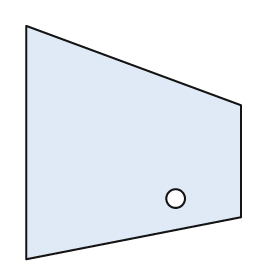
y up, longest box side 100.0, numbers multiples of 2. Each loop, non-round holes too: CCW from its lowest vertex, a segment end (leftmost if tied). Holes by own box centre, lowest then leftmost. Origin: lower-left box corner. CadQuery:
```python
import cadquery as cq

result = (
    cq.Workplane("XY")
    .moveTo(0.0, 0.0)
    .lineTo(92.0, 18.0)
    .lineTo(92.0, 66.0)
    .lineTo(0.0, 100.0)
    .close()
    .moveTo(64.0, 26.0)
    .circle(4.0)
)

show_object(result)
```